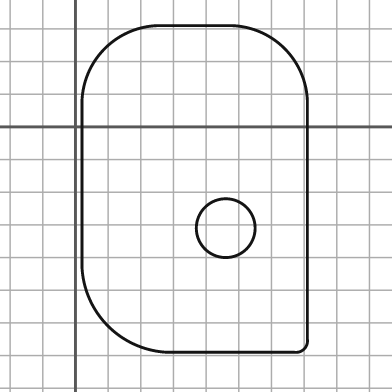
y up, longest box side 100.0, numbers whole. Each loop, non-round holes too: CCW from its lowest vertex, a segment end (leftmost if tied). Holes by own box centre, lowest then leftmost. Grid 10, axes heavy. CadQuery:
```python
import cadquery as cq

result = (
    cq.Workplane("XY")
    .moveTo(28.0, -69.0)
    .lineTo(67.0, -69.0)
    .threePointArc((70.0, -68.0), (71.0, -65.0))
    .lineTo(71.0, 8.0)
    .threePointArc((64.0, 24.0), (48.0, 31.0))
    .lineTo(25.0, 31.0)
    .threePointArc((9.0, 24.0), (2.0, 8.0))
    .lineTo(2.0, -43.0)
    .threePointArc((10.0, -61.0), (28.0, -69.0))
    .close()
    .moveTo(46.0, -31.0)
    .circle(9.0)
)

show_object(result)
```